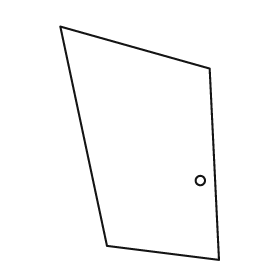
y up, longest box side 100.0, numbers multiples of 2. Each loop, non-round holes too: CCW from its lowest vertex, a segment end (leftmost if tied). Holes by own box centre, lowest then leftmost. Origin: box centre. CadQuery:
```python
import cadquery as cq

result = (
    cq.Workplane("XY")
    .moveTo(34.0, -50.0)
    .lineTo(30.0, 32.0)
    .lineTo(-34.0, 50.0)
    .lineTo(-14.0, -44.0)
    .close()
    .moveTo(26.0, -16.0)
    .circle(2.0)
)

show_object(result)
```